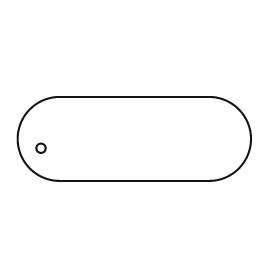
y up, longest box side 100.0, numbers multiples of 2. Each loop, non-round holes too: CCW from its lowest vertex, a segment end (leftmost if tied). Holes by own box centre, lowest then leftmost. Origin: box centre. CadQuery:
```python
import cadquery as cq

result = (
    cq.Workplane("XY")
    .moveTo(-32.0, -18.0)
    .lineTo(32.0, -18.0)
    .threePointArc((50.0, 0.0), (32.0, 18.0))
    .lineTo(-32.0, 18.0)
    .threePointArc((-50.0, 0.0), (-32.0, -18.0))
    .close()
    .moveTo(-40.0, -4.0)
    .circle(2.0)
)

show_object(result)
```